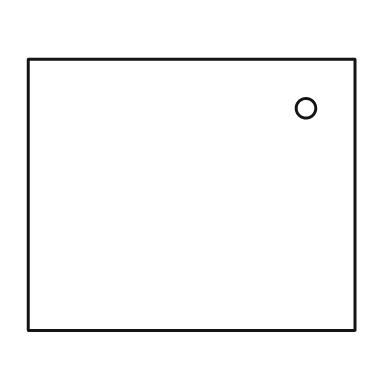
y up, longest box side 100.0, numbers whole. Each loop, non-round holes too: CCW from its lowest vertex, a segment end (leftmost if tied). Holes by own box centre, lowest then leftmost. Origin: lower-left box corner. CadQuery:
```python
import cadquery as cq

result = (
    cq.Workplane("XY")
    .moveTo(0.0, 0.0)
    .lineTo(100.0, 0.0)
    .lineTo(100.0, 83.0)
    .lineTo(0.0, 83.0)
    .close()
    .moveTo(85.0, 68.0)
    .circle(3.0)
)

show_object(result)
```